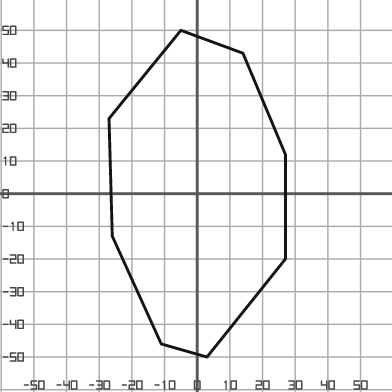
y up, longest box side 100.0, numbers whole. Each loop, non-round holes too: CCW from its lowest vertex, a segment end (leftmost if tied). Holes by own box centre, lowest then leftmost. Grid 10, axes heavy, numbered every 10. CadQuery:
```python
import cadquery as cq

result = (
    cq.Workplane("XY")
    .moveTo(3.0, -50.0)
    .lineTo(27.0, -20.0)
    .lineTo(27.0, 12.0)
    .lineTo(14.0, 43.0)
    .lineTo(-5.0, 50.0)
    .lineTo(-27.0, 23.0)
    .lineTo(-26.0, -13.0)
    .lineTo(-11.0, -46.0)
    .close()
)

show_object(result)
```